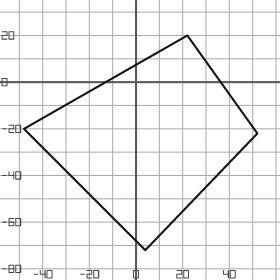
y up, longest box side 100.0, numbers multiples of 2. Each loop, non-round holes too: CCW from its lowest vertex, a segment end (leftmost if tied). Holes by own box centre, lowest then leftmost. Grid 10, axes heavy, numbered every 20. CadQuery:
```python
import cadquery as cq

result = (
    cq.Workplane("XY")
    .moveTo(4.0, -72.0)
    .lineTo(52.0, -22.0)
    .lineTo(22.0, 20.0)
    .lineTo(-48.0, -20.0)
    .close()
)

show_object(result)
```